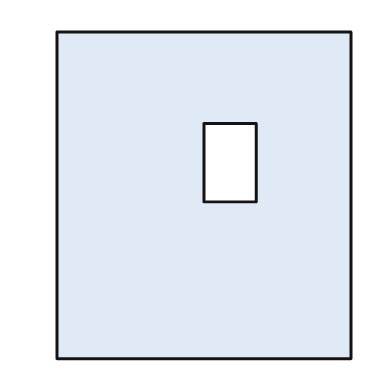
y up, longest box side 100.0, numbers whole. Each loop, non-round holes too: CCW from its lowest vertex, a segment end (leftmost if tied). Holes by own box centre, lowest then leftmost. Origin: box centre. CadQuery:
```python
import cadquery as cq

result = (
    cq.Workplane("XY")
    .moveTo(-45.0, -50.0)
    .lineTo(45.0, -50.0)
    .lineTo(45.0, 50.0)
    .lineTo(-45.0, 50.0)
    .close()
    .moveTo(0.0, -2.0)
    .lineTo(16.0, -2.0)
    .lineTo(16.0, 22.0)
    .lineTo(0.0, 22.0)
    .close()
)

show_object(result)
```